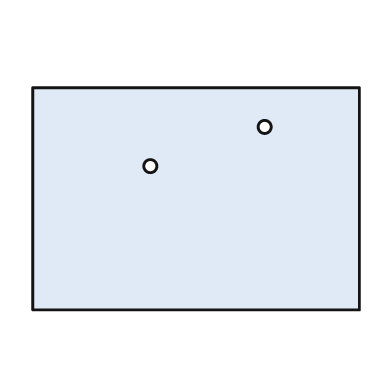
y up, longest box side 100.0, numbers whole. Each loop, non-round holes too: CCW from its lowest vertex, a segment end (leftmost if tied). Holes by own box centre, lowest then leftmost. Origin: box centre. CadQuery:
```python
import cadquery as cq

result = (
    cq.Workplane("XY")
    .moveTo(-50.0, -34.0)
    .lineTo(50.0, -34.0)
    .lineTo(50.0, 34.0)
    .lineTo(-50.0, 34.0)
    .close()
    .moveTo(-14.0, 10.0)
    .circle(2.0)
    .moveTo(21.0, 22.0)
    .circle(2.0)
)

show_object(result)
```